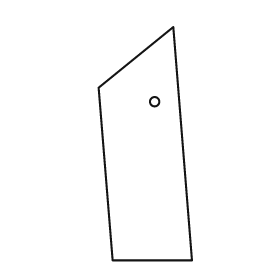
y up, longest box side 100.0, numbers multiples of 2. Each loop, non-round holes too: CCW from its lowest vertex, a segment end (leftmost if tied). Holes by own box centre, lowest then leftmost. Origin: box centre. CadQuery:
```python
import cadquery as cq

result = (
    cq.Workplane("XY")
    .moveTo(-14.0, -50.0)
    .lineTo(20.0, -50.0)
    .lineTo(12.0, 50.0)
    .lineTo(-20.0, 24.0)
    .close()
    .moveTo(4.0, 18.0)
    .circle(2.0)
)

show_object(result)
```